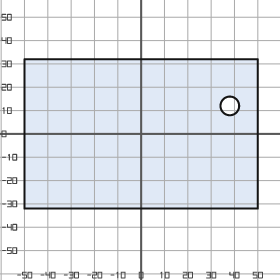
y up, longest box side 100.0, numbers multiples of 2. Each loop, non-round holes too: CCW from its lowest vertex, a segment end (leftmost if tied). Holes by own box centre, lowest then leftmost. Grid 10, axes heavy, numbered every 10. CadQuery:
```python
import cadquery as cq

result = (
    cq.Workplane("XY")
    .moveTo(-50.0, -32.0)
    .lineTo(50.0, -32.0)
    .lineTo(50.0, 32.0)
    .lineTo(-50.0, 32.0)
    .close()
    .moveTo(38.0, 12.0)
    .circle(4.0)
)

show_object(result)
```